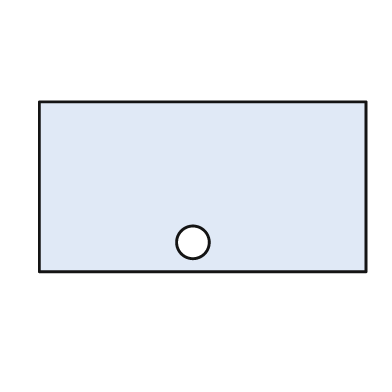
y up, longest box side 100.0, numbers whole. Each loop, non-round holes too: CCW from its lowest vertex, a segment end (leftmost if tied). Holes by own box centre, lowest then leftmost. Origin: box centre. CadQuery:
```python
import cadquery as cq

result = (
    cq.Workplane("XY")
    .moveTo(-50.0, -26.0)
    .lineTo(50.0, -26.0)
    .lineTo(50.0, 26.0)
    .lineTo(-50.0, 26.0)
    .close()
    .moveTo(-3.0, -17.0)
    .circle(5.0)
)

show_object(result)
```